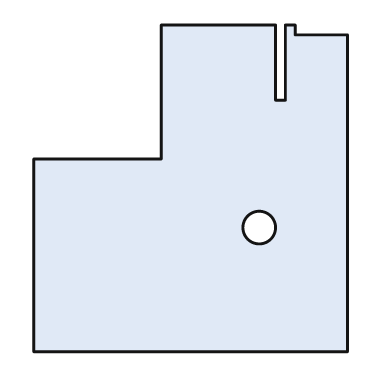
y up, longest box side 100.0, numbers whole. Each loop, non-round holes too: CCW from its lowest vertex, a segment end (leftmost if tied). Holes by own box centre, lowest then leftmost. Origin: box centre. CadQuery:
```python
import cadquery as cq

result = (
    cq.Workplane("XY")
    .moveTo(-48.0, -50.0)
    .lineTo(48.0, -50.0)
    .lineTo(48.0, 47.0)
    .lineTo(32.0, 47.0)
    .lineTo(32.0, 50.0)
    .lineTo(29.0, 50.0)
    .lineTo(29.0, 27.0)
    .lineTo(26.0, 27.0)
    .lineTo(26.0, 50.0)
    .lineTo(-9.0, 50.0)
    .lineTo(-9.0, 9.0)
    .lineTo(-48.0, 9.0)
    .close()
    .moveTo(21.0, -12.0)
    .circle(5.0)
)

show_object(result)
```